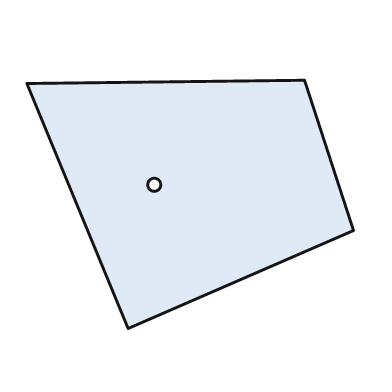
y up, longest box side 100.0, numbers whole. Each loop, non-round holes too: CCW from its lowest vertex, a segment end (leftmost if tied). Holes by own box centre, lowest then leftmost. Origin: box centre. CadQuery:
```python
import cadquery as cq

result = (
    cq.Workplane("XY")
    .moveTo(-19.0, -38.0)
    .lineTo(50.0, -8.0)
    .lineTo(35.0, 38.0)
    .lineTo(-50.0, 37.0)
    .close()
    .moveTo(-11.0, 6.0)
    .circle(2.0)
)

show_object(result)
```